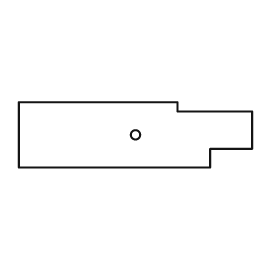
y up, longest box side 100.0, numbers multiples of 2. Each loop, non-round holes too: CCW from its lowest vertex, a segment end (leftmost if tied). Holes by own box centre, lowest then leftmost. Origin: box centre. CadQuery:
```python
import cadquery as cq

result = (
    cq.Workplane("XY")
    .moveTo(-50.0, -14.0)
    .lineTo(32.0, -14.0)
    .lineTo(32.0, -6.0)
    .lineTo(50.0, -6.0)
    .lineTo(50.0, 10.0)
    .lineTo(18.0, 10.0)
    .lineTo(18.0, 14.0)
    .lineTo(-50.0, 14.0)
    .close()
    .moveTo(0.0, 0.0)
    .circle(2.0)
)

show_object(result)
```